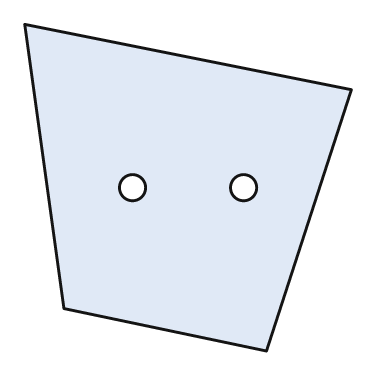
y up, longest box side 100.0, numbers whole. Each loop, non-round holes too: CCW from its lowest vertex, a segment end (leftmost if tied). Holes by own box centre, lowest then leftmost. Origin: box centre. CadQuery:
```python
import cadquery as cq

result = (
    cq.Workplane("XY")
    .moveTo(24.0, -50.0)
    .lineTo(50.0, 30.0)
    .lineTo(-50.0, 50.0)
    .lineTo(-38.0, -37.0)
    .close()
    .moveTo(-17.0, 0.0)
    .circle(4.0)
    .moveTo(17.0, 0.0)
    .circle(4.0)
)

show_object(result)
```